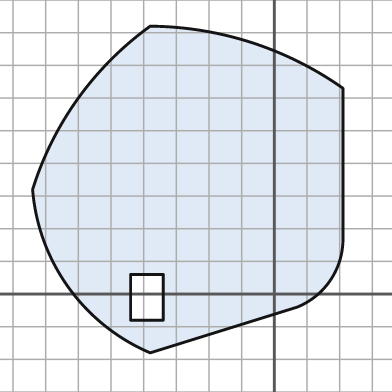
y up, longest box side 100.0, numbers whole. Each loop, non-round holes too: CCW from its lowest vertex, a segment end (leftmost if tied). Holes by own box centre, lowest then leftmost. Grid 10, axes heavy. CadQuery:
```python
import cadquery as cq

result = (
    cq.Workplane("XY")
    .moveTo(-38.0, -18.0)
    .lineTo(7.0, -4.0)
    .threePointArc((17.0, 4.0), (21.0, 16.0))
    .lineTo(21.0, 63.0)
    .threePointArc((-7.0, 77.0), (-38.0, 82.0))
    .threePointArc((-60.0, 60.0), (-74.0, 32.0))
    .threePointArc((-63.0, 2.0), (-38.0, -18.0))
    .close()
    .moveTo(-44.0, -8.0)
    .lineTo(-34.0, -8.0)
    .lineTo(-34.0, 6.0)
    .lineTo(-44.0, 6.0)
    .close()
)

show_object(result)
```